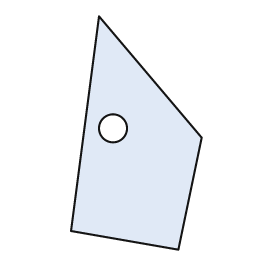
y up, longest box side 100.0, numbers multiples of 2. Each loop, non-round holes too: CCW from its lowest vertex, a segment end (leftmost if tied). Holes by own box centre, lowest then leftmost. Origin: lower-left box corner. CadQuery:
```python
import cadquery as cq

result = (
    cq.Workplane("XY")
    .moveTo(46.0, 0.0)
    .lineTo(56.0, 48.0)
    .lineTo(12.0, 100.0)
    .lineTo(0.0, 8.0)
    .close()
    .moveTo(18.0, 52.0)
    .circle(6.0)
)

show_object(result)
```